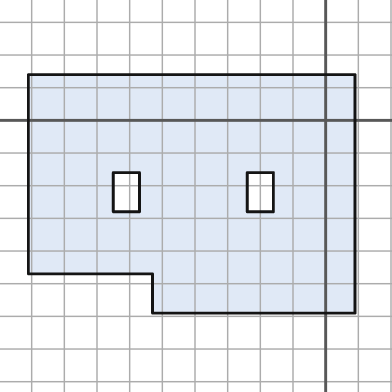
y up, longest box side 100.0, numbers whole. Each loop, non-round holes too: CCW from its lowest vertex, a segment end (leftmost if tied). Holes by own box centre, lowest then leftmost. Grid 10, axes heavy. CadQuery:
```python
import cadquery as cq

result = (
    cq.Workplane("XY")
    .moveTo(-53.0, -59.0)
    .lineTo(9.0, -59.0)
    .lineTo(9.0, 14.0)
    .lineTo(-91.0, 14.0)
    .lineTo(-91.0, -47.0)
    .lineTo(-53.0, -47.0)
    .close()
    .moveTo(-65.0, -28.0)
    .lineTo(-57.0, -28.0)
    .lineTo(-57.0, -16.0)
    .lineTo(-65.0, -16.0)
    .close()
    .moveTo(-24.0, -28.0)
    .lineTo(-16.0, -28.0)
    .lineTo(-16.0, -16.0)
    .lineTo(-24.0, -16.0)
    .close()
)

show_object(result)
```